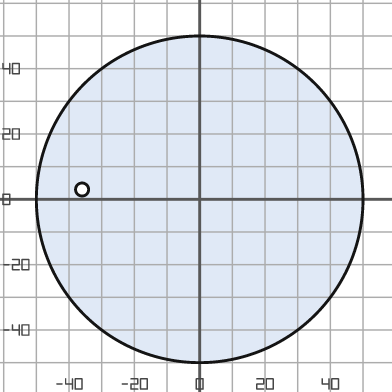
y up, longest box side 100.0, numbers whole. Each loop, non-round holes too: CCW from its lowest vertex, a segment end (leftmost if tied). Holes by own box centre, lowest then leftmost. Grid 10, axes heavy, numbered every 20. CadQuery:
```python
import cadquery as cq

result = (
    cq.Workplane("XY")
    .moveTo(0.0, 0.0)
    .circle(50.0)
    .moveTo(-36.0, 3.0)
    .circle(2.0)
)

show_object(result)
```